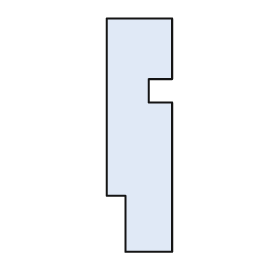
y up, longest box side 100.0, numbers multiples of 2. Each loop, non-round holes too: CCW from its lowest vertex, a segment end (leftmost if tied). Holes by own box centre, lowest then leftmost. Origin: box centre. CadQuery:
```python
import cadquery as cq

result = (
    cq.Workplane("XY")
    .moveTo(-6.0, -50.0)
    .lineTo(14.0, -50.0)
    .lineTo(14.0, 14.0)
    .lineTo(4.0, 14.0)
    .lineTo(4.0, 24.0)
    .lineTo(14.0, 24.0)
    .lineTo(14.0, 50.0)
    .lineTo(-14.0, 50.0)
    .lineTo(-14.0, -26.0)
    .lineTo(-6.0, -26.0)
    .close()
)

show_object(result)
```